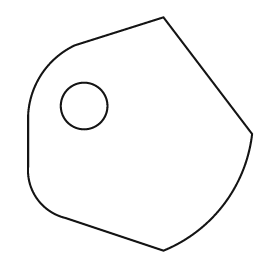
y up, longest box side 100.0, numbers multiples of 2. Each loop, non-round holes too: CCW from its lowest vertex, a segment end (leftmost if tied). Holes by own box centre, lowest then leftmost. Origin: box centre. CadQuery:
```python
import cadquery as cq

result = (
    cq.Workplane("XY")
    .moveTo(10.0, -50.0)
    .threePointArc((36.0, -30.0), (48.0, 0.0))
    .lineTo(10.0, 50.0)
    .lineTo(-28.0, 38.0)
    .threePointArc((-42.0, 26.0), (-48.0, 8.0))
    .lineTo(-48.0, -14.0)
    .threePointArc((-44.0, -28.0), (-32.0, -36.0))
    .close()
    .moveTo(-24.0, 12.0)
    .circle(10.0)
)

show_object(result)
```